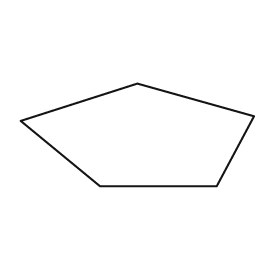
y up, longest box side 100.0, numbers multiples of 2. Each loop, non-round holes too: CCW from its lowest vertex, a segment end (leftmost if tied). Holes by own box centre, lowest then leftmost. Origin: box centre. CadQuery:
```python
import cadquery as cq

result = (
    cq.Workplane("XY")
    .moveTo(-16.0, -22.0)
    .lineTo(34.0, -22.0)
    .lineTo(50.0, 8.0)
    .lineTo(0.0, 22.0)
    .lineTo(-50.0, 6.0)
    .close()
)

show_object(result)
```